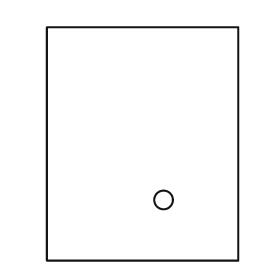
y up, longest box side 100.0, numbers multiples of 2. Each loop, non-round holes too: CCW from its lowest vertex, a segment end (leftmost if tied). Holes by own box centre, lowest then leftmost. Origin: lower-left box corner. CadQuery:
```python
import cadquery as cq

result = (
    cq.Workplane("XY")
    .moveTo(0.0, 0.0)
    .lineTo(82.0, 0.0)
    .lineTo(82.0, 100.0)
    .lineTo(0.0, 100.0)
    .close()
    .moveTo(50.0, 26.0)
    .circle(4.0)
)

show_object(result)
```